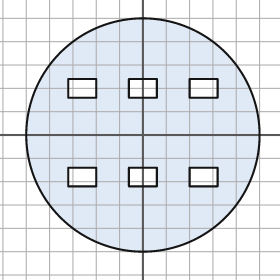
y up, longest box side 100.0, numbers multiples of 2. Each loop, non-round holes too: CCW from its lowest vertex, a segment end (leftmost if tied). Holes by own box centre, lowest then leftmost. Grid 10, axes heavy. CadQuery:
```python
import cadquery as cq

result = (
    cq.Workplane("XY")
    .moveTo(0.0, 0.0)
    .circle(50.0)
    .moveTo(-32.0, -22.0)
    .lineTo(-20.0, -22.0)
    .lineTo(-20.0, -14.0)
    .lineTo(-32.0, -14.0)
    .close()
    .moveTo(-6.0, -22.0)
    .lineTo(6.0, -22.0)
    .lineTo(6.0, -14.0)
    .lineTo(-6.0, -14.0)
    .close()
    .moveTo(20.0, -22.0)
    .lineTo(32.0, -22.0)
    .lineTo(32.0, -14.0)
    .lineTo(20.0, -14.0)
    .close()
    .moveTo(-32.0, 16.0)
    .lineTo(-20.0, 16.0)
    .lineTo(-20.0, 24.0)
    .lineTo(-32.0, 24.0)
    .close()
    .moveTo(-6.0, 16.0)
    .lineTo(6.0, 16.0)
    .lineTo(6.0, 24.0)
    .lineTo(-6.0, 24.0)
    .close()
    .moveTo(20.0, 16.0)
    .lineTo(32.0, 16.0)
    .lineTo(32.0, 24.0)
    .lineTo(20.0, 24.0)
    .close()
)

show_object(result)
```